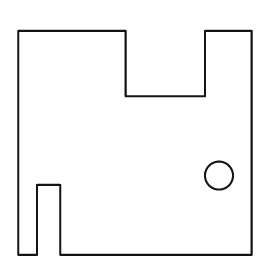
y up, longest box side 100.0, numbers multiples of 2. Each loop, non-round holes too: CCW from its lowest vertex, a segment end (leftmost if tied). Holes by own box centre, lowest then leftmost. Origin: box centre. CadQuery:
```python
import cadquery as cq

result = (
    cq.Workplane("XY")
    .moveTo(-50.0, -48.0)
    .lineTo(-42.0, -48.0)
    .lineTo(-42.0, -18.0)
    .lineTo(-32.0, -18.0)
    .lineTo(-32.0, -48.0)
    .lineTo(50.0, -48.0)
    .lineTo(50.0, 48.0)
    .lineTo(30.0, 48.0)
    .lineTo(30.0, 20.0)
    .lineTo(-4.0, 20.0)
    .lineTo(-4.0, 48.0)
    .lineTo(-50.0, 48.0)
    .close()
    .moveTo(36.0, -14.0)
    .circle(6.0)
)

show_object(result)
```